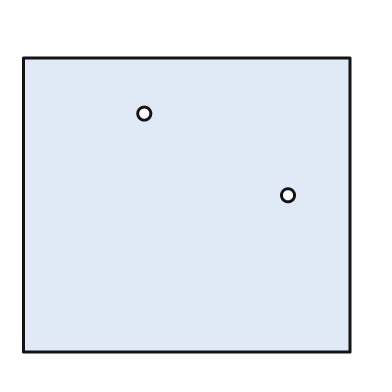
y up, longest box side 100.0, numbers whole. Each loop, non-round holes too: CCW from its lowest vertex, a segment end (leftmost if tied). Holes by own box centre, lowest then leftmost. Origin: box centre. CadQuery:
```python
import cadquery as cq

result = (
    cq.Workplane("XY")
    .moveTo(-50.0, -45.0)
    .lineTo(50.0, -45.0)
    .lineTo(50.0, 45.0)
    .lineTo(-50.0, 45.0)
    .close()
    .moveTo(31.0, 3.0)
    .circle(2.0)
    .moveTo(-13.0, 28.0)
    .circle(2.0)
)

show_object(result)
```